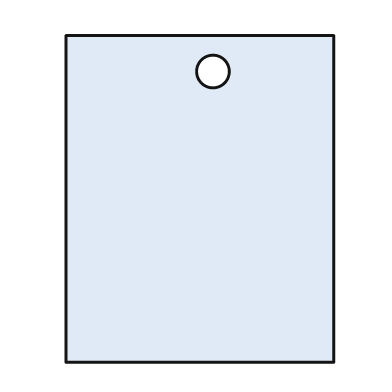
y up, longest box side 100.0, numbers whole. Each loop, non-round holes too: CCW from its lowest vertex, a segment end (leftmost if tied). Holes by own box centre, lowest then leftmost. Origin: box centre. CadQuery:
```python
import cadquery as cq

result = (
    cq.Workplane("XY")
    .moveTo(-41.0, -50.0)
    .lineTo(41.0, -50.0)
    .lineTo(41.0, 50.0)
    .lineTo(-41.0, 50.0)
    .close()
    .moveTo(4.0, 39.0)
    .circle(5.0)
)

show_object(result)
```